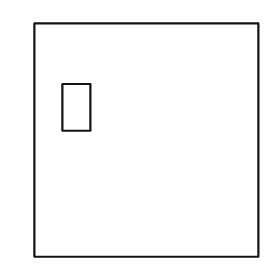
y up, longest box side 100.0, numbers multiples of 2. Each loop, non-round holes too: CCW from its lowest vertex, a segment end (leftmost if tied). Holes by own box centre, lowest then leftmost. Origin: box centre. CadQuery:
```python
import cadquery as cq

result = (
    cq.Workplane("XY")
    .moveTo(-48.0, -50.0)
    .lineTo(48.0, -50.0)
    .lineTo(48.0, 50.0)
    .lineTo(-48.0, 50.0)
    .close()
    .moveTo(-36.0, 4.0)
    .lineTo(-24.0, 4.0)
    .lineTo(-24.0, 24.0)
    .lineTo(-36.0, 24.0)
    .close()
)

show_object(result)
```